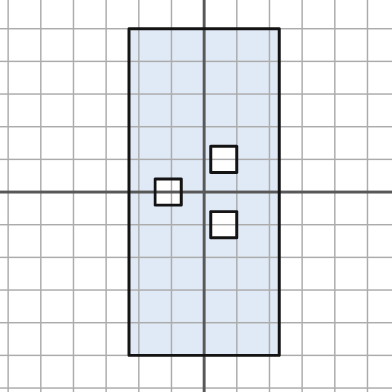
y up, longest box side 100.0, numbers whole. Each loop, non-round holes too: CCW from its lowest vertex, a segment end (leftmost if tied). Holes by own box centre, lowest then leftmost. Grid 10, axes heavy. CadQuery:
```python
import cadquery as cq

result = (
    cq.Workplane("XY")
    .moveTo(-23.0, -50.0)
    .lineTo(23.0, -50.0)
    .lineTo(23.0, 50.0)
    .lineTo(-23.0, 50.0)
    .close()
    .moveTo(2.0, -14.0)
    .lineTo(10.0, -14.0)
    .lineTo(10.0, -6.0)
    .lineTo(2.0, -6.0)
    .close()
    .moveTo(-15.0, -4.0)
    .lineTo(-7.0, -4.0)
    .lineTo(-7.0, 4.0)
    .lineTo(-15.0, 4.0)
    .close()
    .moveTo(2.0, 6.0)
    .lineTo(10.0, 6.0)
    .lineTo(10.0, 14.0)
    .lineTo(2.0, 14.0)
    .close()
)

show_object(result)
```